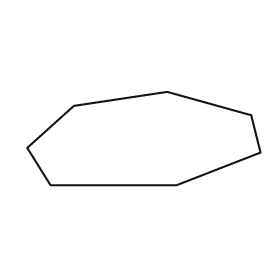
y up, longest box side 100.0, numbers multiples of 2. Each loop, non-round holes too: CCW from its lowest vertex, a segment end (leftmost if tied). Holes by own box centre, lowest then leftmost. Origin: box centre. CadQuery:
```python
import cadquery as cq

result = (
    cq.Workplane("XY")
    .moveTo(-40.0, -20.0)
    .lineTo(14.0, -20.0)
    .lineTo(50.0, -6.0)
    .lineTo(46.0, 10.0)
    .lineTo(10.0, 20.0)
    .lineTo(-30.0, 14.0)
    .lineTo(-50.0, -4.0)
    .close()
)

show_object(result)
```